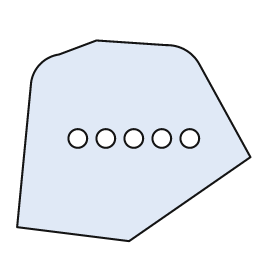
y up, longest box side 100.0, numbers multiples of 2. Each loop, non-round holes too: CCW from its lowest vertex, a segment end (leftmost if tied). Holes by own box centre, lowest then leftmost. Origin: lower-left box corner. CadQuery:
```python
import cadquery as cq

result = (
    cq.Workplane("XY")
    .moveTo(48.0, 0.0)
    .lineTo(100.0, 36.0)
    .lineTo(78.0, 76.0)
    .threePointArc((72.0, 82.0), (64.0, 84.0))
    .lineTo(34.0, 86.0)
    .lineTo(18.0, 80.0)
    .threePointArc((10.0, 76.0), (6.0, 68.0))
    .lineTo(0.0, 6.0)
    .close()
    .moveTo(26.0, 44.0)
    .circle(4.0)
    .moveTo(38.0, 44.0)
    .circle(4.0)
    .moveTo(50.0, 44.0)
    .circle(4.0)
    .moveTo(62.0, 44.0)
    .circle(4.0)
    .moveTo(74.0, 44.0)
    .circle(4.0)
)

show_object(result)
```